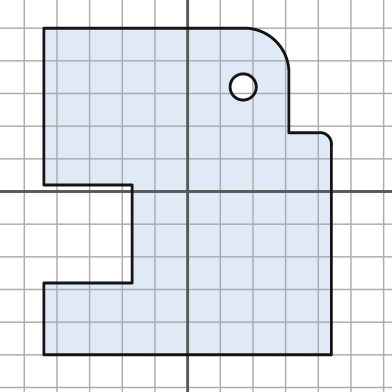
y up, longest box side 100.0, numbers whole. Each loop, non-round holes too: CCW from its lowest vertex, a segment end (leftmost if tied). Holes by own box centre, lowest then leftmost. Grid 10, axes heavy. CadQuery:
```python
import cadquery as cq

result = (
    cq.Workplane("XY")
    .moveTo(-44.0, -50.0)
    .lineTo(44.0, -50.0)
    .lineTo(44.0, 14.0)
    .threePointArc((43.0, 17.0), (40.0, 18.0))
    .lineTo(31.0, 18.0)
    .lineTo(31.0, 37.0)
    .threePointArc((27.0, 46.0), (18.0, 50.0))
    .lineTo(-44.0, 50.0)
    .lineTo(-44.0, 2.0)
    .lineTo(-17.0, 2.0)
    .lineTo(-17.0, -28.0)
    .lineTo(-44.0, -28.0)
    .close()
    .moveTo(17.0, 32.0)
    .circle(4.0)
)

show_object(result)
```